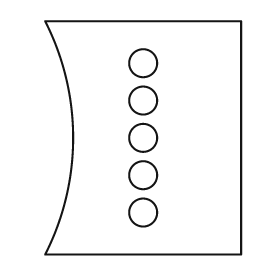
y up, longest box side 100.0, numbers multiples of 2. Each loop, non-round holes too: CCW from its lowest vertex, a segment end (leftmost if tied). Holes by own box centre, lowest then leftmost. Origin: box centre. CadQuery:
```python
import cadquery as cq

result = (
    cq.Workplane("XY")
    .moveTo(-42.0, -50.0)
    .lineTo(42.0, -50.0)
    .lineTo(42.0, 50.0)
    .lineTo(-42.0, 50.0)
    .threePointArc((-30.0, 0.0), (-42.0, -50.0))
    .close()
    .moveTo(0.0, -32.0)
    .circle(6.0)
    .moveTo(0.0, -16.0)
    .circle(6.0)
    .moveTo(0.0, 0.0)
    .circle(6.0)
    .moveTo(0.0, 16.0)
    .circle(6.0)
    .moveTo(0.0, 32.0)
    .circle(6.0)
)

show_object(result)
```